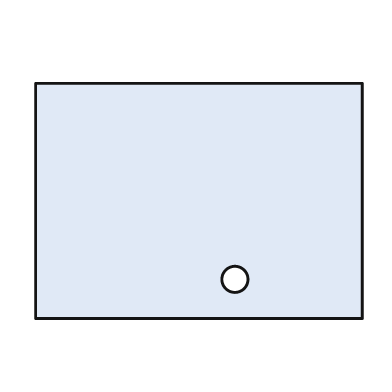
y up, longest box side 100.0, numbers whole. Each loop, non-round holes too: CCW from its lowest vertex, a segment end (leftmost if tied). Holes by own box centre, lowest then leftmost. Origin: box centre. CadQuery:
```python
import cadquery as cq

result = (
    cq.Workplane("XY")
    .moveTo(-50.0, -36.0)
    .lineTo(50.0, -36.0)
    .lineTo(50.0, 36.0)
    .lineTo(-50.0, 36.0)
    .close()
    .moveTo(11.0, -24.0)
    .circle(4.0)
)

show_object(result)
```